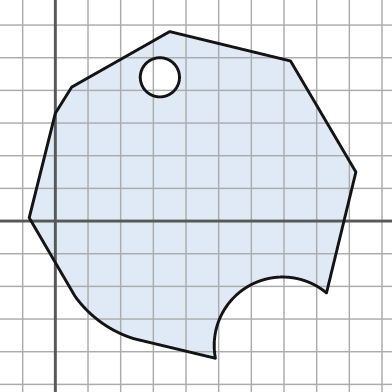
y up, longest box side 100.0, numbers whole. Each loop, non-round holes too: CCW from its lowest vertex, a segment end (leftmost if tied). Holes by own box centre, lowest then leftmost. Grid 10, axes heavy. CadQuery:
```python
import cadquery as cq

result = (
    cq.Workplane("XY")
    .moveTo(49.0, -42.0)
    .threePointArc((59.0, -20.0), (83.0, -22.0))
    .lineTo(92.0, 15.0)
    .lineTo(72.0, 49.0)
    .lineTo(35.0, 58.0)
    .lineTo(5.0, 41.0)
    .lineTo(0.0, 33.0)
    .lineTo(-8.0, 1.0)
    .lineTo(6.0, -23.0)
    .threePointArc((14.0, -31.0), (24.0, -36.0))
    .close()
    .moveTo(32.0, 44.0)
    .circle(6.0)
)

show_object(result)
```